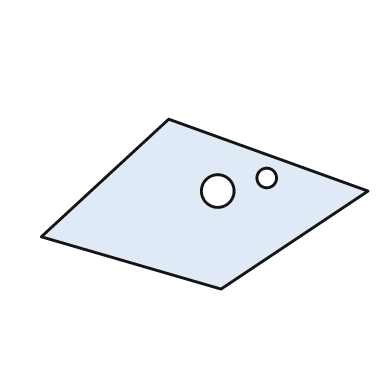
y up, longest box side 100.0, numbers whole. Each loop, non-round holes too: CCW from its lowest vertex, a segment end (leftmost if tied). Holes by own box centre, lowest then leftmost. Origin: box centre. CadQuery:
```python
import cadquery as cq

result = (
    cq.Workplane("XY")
    .moveTo(5.0, -26.0)
    .lineTo(50.0, 4.0)
    .lineTo(-11.0, 26.0)
    .lineTo(-50.0, -10.0)
    .close()
    .moveTo(4.0, 4.0)
    .circle(5.0)
    .moveTo(19.0, 8.0)
    .circle(3.0)
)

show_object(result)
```